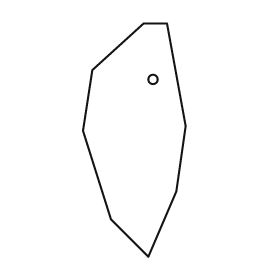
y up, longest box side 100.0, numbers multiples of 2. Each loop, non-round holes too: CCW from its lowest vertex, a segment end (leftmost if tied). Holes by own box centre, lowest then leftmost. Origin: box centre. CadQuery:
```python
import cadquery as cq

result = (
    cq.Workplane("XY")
    .moveTo(6.0, -50.0)
    .lineTo(18.0, -22.0)
    .lineTo(22.0, 6.0)
    .lineTo(14.0, 50.0)
    .lineTo(4.0, 50.0)
    .lineTo(-18.0, 30.0)
    .lineTo(-22.0, 4.0)
    .lineTo(-10.0, -34.0)
    .close()
    .moveTo(8.0, 26.0)
    .circle(2.0)
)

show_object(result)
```